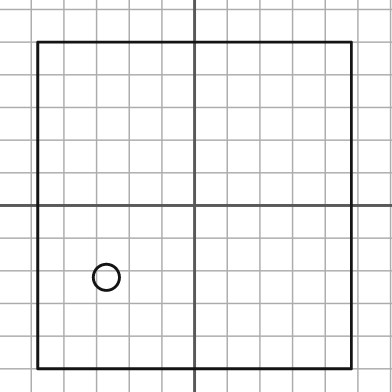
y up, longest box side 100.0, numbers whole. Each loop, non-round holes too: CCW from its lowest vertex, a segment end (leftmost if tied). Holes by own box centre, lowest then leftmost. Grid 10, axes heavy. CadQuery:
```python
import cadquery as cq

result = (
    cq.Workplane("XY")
    .moveTo(-48.0, -50.0)
    .lineTo(48.0, -50.0)
    .lineTo(48.0, 50.0)
    .lineTo(-48.0, 50.0)
    .close()
    .moveTo(-27.0, -22.0)
    .circle(4.0)
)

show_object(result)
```